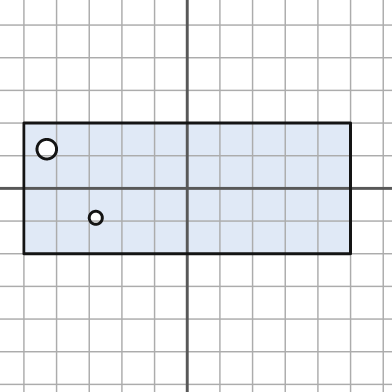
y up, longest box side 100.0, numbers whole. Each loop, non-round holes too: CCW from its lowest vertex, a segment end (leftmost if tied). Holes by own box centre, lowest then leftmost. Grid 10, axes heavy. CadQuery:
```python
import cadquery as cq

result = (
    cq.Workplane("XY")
    .moveTo(-50.0, -20.0)
    .lineTo(50.0, -20.0)
    .lineTo(50.0, 20.0)
    .lineTo(-50.0, 20.0)
    .close()
    .moveTo(-28.0, -9.0)
    .circle(2.0)
    .moveTo(-43.0, 12.0)
    .circle(3.0)
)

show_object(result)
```